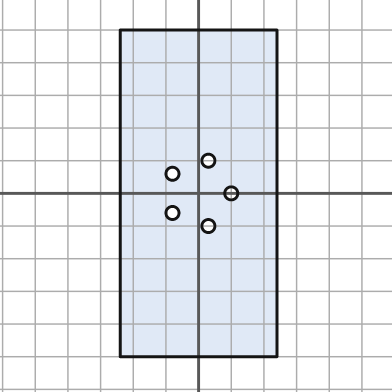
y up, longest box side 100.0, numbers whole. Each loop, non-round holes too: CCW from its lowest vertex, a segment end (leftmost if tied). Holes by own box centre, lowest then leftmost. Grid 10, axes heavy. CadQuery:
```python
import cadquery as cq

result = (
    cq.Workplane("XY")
    .moveTo(-24.0, -50.0)
    .lineTo(24.0, -50.0)
    .lineTo(24.0, 50.0)
    .lineTo(-24.0, 50.0)
    .close()
    .moveTo(3.0, -10.0)
    .circle(2.0)
    .moveTo(-8.0, -6.0)
    .circle(2.0)
    .moveTo(10.0, 0.0)
    .circle(2.0)
    .moveTo(-8.0, 6.0)
    .circle(2.0)
    .moveTo(3.0, 10.0)
    .circle(2.0)
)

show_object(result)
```